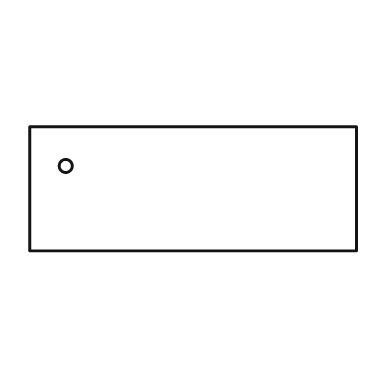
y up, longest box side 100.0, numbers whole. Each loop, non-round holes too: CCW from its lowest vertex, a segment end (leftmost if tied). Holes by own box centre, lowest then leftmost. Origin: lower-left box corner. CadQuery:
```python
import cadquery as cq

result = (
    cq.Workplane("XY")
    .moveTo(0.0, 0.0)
    .lineTo(100.0, 0.0)
    .lineTo(100.0, 38.0)
    .lineTo(0.0, 38.0)
    .close()
    .moveTo(11.0, 26.0)
    .circle(2.0)
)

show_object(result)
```